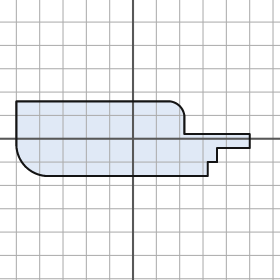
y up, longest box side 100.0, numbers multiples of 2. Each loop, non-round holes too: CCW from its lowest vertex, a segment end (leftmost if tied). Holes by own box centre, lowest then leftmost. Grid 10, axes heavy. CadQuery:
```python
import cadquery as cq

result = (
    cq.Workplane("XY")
    .moveTo(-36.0, -16.0)
    .lineTo(32.0, -16.0)
    .lineTo(32.0, -10.0)
    .lineTo(36.0, -10.0)
    .lineTo(36.0, -4.0)
    .lineTo(50.0, -4.0)
    .lineTo(50.0, 2.0)
    .lineTo(22.0, 2.0)
    .lineTo(22.0, 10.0)
    .threePointArc((20.0, 14.0), (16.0, 16.0))
    .lineTo(-50.0, 16.0)
    .lineTo(-50.0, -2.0)
    .threePointArc((-46.0, -12.0), (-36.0, -16.0))
    .close()
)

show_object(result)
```